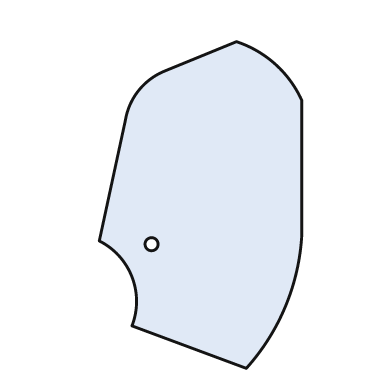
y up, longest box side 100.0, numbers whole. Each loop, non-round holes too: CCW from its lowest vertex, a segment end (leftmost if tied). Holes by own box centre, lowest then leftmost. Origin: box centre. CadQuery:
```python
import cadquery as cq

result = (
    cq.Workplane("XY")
    .moveTo(14.0, -50.0)
    .threePointArc((26.0, -31.0), (31.0, -9.0))
    .lineTo(31.0, 32.0)
    .threePointArc((23.0, 43.0), (11.0, 50.0))
    .lineTo(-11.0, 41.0)
    .threePointArc((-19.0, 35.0), (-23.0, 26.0))
    .lineTo(-31.0, -11.0)
    .threePointArc((-21.0, -22.0), (-21.0, -37.0))
    .close()
    .moveTo(-15.0, -12.0)
    .circle(2.0)
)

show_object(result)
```